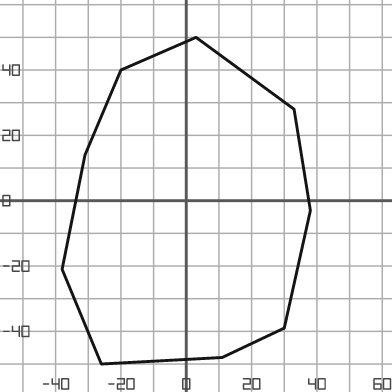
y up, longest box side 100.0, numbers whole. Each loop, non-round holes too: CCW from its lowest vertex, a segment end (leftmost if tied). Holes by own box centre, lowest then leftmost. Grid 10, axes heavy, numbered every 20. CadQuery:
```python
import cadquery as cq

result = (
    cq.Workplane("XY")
    .moveTo(-26.0, -50.0)
    .lineTo(11.0, -48.0)
    .lineTo(30.0, -39.0)
    .lineTo(38.0, -3.0)
    .lineTo(33.0, 28.0)
    .lineTo(3.0, 50.0)
    .lineTo(-20.0, 40.0)
    .lineTo(-31.0, 14.0)
    .lineTo(-38.0, -21.0)
    .close()
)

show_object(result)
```